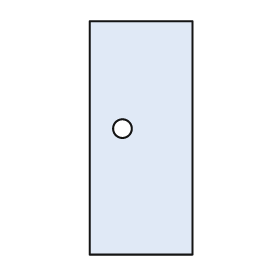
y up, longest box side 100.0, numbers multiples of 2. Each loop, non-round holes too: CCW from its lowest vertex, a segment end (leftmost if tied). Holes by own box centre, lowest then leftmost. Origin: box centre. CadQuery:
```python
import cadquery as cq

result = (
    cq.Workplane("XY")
    .moveTo(-22.0, -50.0)
    .lineTo(22.0, -50.0)
    .lineTo(22.0, 50.0)
    .lineTo(-22.0, 50.0)
    .close()
    .moveTo(-8.0, 4.0)
    .circle(4.0)
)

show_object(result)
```